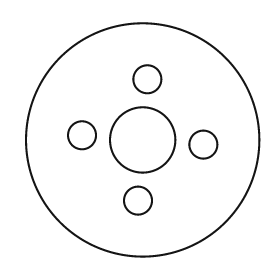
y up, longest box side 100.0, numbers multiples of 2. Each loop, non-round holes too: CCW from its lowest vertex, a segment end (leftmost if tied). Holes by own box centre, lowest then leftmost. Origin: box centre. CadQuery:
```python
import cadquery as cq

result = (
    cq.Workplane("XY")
    .moveTo(0.0, 0.0)
    .circle(50.0)
    .moveTo(-2.0, -26.0)
    .circle(6.0)
    .moveTo(26.0, -2.0)
    .circle(6.0)
    .moveTo(0.0, 0.0)
    .circle(14.0)
    .moveTo(-26.0, 2.0)
    .circle(6.0)
    .moveTo(2.0, 26.0)
    .circle(6.0)
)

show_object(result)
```